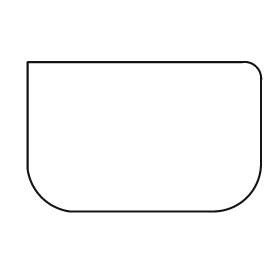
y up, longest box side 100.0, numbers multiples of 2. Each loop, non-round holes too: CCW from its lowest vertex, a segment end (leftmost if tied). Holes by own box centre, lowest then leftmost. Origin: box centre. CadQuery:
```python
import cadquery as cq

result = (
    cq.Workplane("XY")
    .moveTo(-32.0, -32.0)
    .lineTo(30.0, -32.0)
    .threePointArc((44.0, -26.0), (50.0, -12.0))
    .lineTo(50.0, 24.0)
    .threePointArc((48.0, 30.0), (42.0, 32.0))
    .lineTo(-50.0, 32.0)
    .lineTo(-50.0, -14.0)
    .threePointArc((-44.0, -26.0), (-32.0, -32.0))
    .close()
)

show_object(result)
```